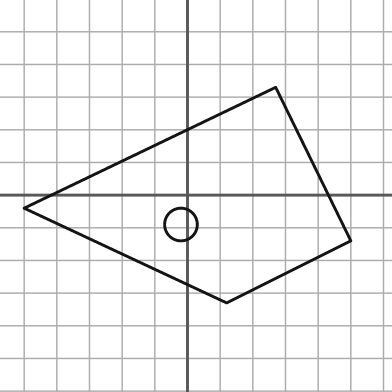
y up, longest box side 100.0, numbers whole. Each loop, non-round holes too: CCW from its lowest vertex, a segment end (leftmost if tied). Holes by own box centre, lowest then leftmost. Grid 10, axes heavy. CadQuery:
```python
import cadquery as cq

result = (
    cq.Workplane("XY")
    .moveTo(12.0, -33.0)
    .lineTo(50.0, -14.0)
    .lineTo(27.0, 33.0)
    .lineTo(-50.0, -4.0)
    .close()
    .moveTo(-2.0, -9.0)
    .circle(5.0)
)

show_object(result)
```